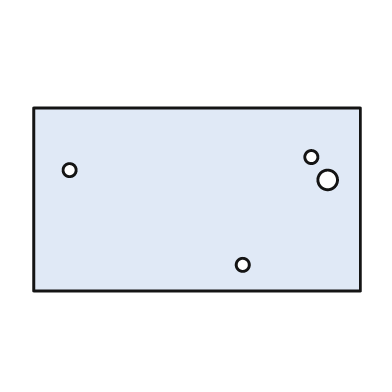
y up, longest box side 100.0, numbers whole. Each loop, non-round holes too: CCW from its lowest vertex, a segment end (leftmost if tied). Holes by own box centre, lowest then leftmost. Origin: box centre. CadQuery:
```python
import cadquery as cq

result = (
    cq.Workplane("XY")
    .moveTo(-50.0, -28.0)
    .lineTo(50.0, -28.0)
    .lineTo(50.0, 28.0)
    .lineTo(-50.0, 28.0)
    .close()
    .moveTo(14.0, -20.0)
    .circle(2.0)
    .moveTo(40.0, 6.0)
    .circle(3.0)
    .moveTo(-39.0, 9.0)
    .circle(2.0)
    .moveTo(35.0, 13.0)
    .circle(2.0)
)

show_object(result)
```